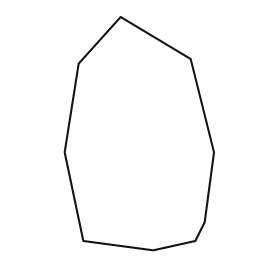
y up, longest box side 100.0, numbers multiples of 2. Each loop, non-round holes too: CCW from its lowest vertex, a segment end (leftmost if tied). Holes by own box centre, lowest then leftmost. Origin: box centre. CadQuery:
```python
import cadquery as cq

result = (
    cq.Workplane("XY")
    .moveTo(6.0, -50.0)
    .lineTo(24.0, -46.0)
    .lineTo(28.0, -38.0)
    .lineTo(32.0, -8.0)
    .lineTo(22.0, 32.0)
    .lineTo(-8.0, 50.0)
    .lineTo(-26.0, 30.0)
    .lineTo(-32.0, -8.0)
    .lineTo(-24.0, -46.0)
    .close()
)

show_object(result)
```